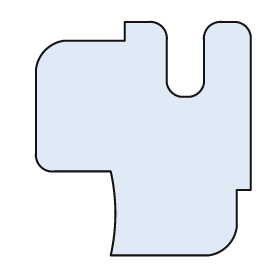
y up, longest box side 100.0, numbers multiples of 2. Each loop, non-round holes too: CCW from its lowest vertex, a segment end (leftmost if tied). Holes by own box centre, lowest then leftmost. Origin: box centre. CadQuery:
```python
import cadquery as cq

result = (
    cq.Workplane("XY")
    .moveTo(-14.0, -50.0)
    .lineTo(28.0, -50.0)
    .threePointArc((36.0, -46.0), (40.0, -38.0))
    .lineTo(40.0, -22.0)
    .lineTo(46.0, -22.0)
    .lineTo(46.0, 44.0)
    .threePointArc((44.0, 48.0), (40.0, 50.0))
    .lineTo(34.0, 50.0)
    .threePointArc((28.0, 48.0), (26.0, 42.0))
    .lineTo(26.0, 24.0)
    .threePointArc((24.0, 20.0), (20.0, 18.0))
    .lineTo(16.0, 18.0)
    .threePointArc((12.0, 20.0), (10.0, 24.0))
    .lineTo(10.0, 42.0)
    .threePointArc((8.0, 48.0), (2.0, 50.0))
    .lineTo(-8.0, 50.0)
    .lineTo(-8.0, 42.0)
    .lineTo(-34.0, 42.0)
    .threePointArc((-42.0, 38.0), (-46.0, 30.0))
    .lineTo(-46.0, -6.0)
    .threePointArc((-44.0, -12.0), (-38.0, -14.0))
    .lineTo(-14.0, -14.0)
    .threePointArc((-12.0, -32.0), (-14.0, -50.0))
    .close()
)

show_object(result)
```